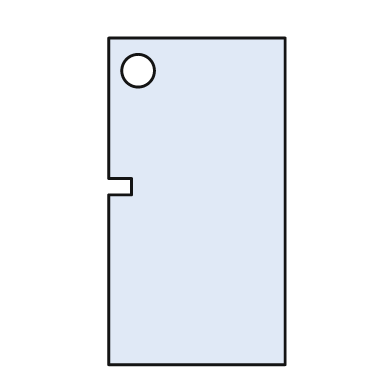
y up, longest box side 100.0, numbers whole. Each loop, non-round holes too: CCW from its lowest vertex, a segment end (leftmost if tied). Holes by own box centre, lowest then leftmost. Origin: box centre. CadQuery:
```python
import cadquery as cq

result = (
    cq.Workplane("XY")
    .moveTo(-27.0, -50.0)
    .lineTo(27.0, -50.0)
    .lineTo(27.0, 50.0)
    .lineTo(-27.0, 50.0)
    .lineTo(-27.0, 7.0)
    .lineTo(-20.0, 7.0)
    .lineTo(-20.0, 2.0)
    .lineTo(-27.0, 2.0)
    .close()
    .moveTo(-18.0, 40.0)
    .circle(5.0)
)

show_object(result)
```